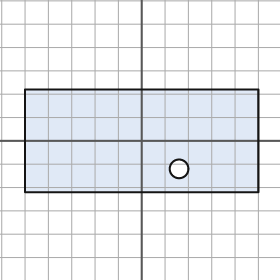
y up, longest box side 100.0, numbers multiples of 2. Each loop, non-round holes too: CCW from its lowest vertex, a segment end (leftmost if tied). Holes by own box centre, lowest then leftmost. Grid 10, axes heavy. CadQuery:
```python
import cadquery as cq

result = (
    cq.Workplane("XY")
    .moveTo(-50.0, -22.0)
    .lineTo(50.0, -22.0)
    .lineTo(50.0, 22.0)
    .lineTo(-50.0, 22.0)
    .close()
    .moveTo(16.0, -12.0)
    .circle(4.0)
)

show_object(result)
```